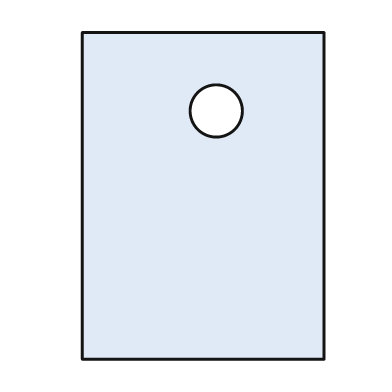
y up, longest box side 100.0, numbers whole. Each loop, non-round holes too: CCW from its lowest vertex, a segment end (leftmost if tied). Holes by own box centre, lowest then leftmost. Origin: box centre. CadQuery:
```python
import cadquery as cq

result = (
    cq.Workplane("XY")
    .moveTo(-37.0, -50.0)
    .lineTo(37.0, -50.0)
    .lineTo(37.0, 50.0)
    .lineTo(-37.0, 50.0)
    .close()
    .moveTo(4.0, 26.0)
    .circle(8.0)
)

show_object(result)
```